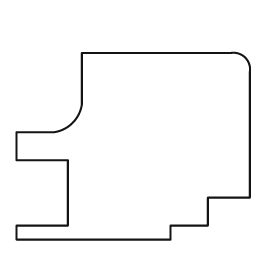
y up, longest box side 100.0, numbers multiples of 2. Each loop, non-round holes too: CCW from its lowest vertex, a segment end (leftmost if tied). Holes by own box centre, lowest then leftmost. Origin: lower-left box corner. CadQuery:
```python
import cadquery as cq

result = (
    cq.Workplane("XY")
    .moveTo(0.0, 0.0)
    .lineTo(66.0, 0.0)
    .lineTo(66.0, 6.0)
    .lineTo(82.0, 6.0)
    .lineTo(82.0, 18.0)
    .lineTo(100.0, 18.0)
    .lineTo(100.0, 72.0)
    .threePointArc((98.0, 78.0), (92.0, 80.0))
    .lineTo(28.0, 80.0)
    .lineTo(28.0, 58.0)
    .threePointArc((24.0, 50.0), (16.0, 46.0))
    .lineTo(0.0, 46.0)
    .lineTo(0.0, 34.0)
    .lineTo(22.0, 34.0)
    .lineTo(22.0, 6.0)
    .lineTo(0.0, 6.0)
    .close()
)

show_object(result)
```